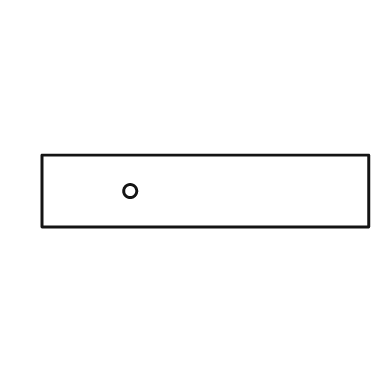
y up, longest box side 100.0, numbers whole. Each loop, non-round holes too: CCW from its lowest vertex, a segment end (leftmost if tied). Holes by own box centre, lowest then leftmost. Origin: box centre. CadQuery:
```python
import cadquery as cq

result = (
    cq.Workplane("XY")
    .moveTo(-50.0, -11.0)
    .lineTo(50.0, -11.0)
    .lineTo(50.0, 11.0)
    .lineTo(-50.0, 11.0)
    .close()
    .moveTo(-23.0, 0.0)
    .circle(2.0)
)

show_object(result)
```